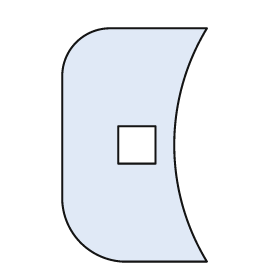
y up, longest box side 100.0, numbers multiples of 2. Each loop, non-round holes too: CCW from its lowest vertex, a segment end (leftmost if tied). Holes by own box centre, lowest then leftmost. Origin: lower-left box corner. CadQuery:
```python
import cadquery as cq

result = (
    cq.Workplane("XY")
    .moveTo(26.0, 0.0)
    .lineTo(62.0, 0.0)
    .threePointArc((48.0, 50.0), (62.0, 100.0))
    .lineTo(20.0, 100.0)
    .threePointArc((6.0, 94.0), (0.0, 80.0))
    .lineTo(0.0, 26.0)
    .threePointArc((8.0, 8.0), (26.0, 0.0))
    .close()
    .moveTo(24.0, 42.0)
    .lineTo(40.0, 42.0)
    .lineTo(40.0, 58.0)
    .lineTo(24.0, 58.0)
    .close()
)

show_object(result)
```